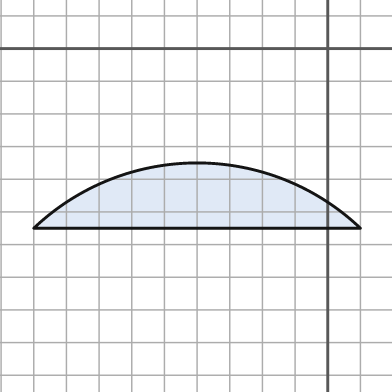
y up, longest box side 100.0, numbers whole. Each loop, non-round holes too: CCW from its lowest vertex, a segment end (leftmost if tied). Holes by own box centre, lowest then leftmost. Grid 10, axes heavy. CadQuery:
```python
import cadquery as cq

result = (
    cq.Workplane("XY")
    .moveTo(-90.0, -55.0)
    .lineTo(10.0, -55.0)
    .threePointArc((-40.0, -35.0), (-90.0, -55.0))
    .close()
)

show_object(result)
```